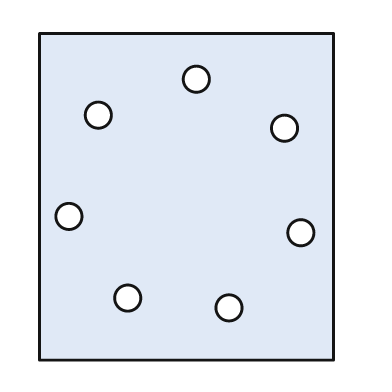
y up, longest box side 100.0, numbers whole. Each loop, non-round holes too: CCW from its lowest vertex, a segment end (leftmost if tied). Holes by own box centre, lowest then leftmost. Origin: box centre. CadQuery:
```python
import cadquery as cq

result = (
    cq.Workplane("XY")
    .moveTo(-45.0, -50.0)
    .lineTo(45.0, -50.0)
    .lineTo(45.0, 50.0)
    .lineTo(-45.0, 50.0)
    .close()
    .moveTo(13.0, -34.0)
    .circle(4.0)
    .moveTo(-18.0, -31.0)
    .circle(4.0)
    .moveTo(35.0, -11.0)
    .circle(4.0)
    .moveTo(-36.0, -6.0)
    .circle(4.0)
    .moveTo(30.0, 21.0)
    .circle(4.0)
    .moveTo(-27.0, 25.0)
    .circle(4.0)
    .moveTo(3.0, 36.0)
    .circle(4.0)
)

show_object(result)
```